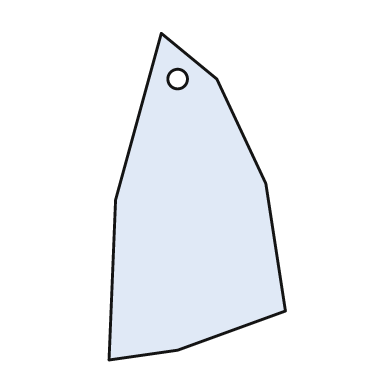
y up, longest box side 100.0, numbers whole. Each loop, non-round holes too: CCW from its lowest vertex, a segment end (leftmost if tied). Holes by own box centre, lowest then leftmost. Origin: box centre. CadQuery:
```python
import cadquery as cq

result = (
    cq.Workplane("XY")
    .moveTo(-27.0, -50.0)
    .lineTo(-6.0, -47.0)
    .lineTo(27.0, -35.0)
    .lineTo(21.0, 4.0)
    .lineTo(6.0, 36.0)
    .lineTo(-11.0, 50.0)
    .lineTo(-25.0, -1.0)
    .close()
    .moveTo(-6.0, 36.0)
    .circle(3.0)
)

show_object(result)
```